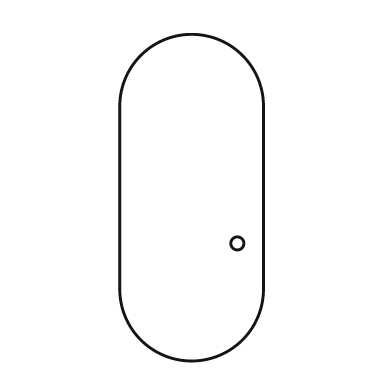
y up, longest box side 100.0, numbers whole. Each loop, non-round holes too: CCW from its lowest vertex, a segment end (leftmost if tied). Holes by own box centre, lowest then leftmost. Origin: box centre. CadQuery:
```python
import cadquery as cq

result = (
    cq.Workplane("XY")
    .moveTo(-22.0, -28.0)
    .threePointArc((0.0, -50.0), (22.0, -28.0))
    .lineTo(22.0, 28.0)
    .threePointArc((0.0, 50.0), (-22.0, 28.0))
    .close()
    .moveTo(14.0, -14.0)
    .circle(2.0)
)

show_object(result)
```